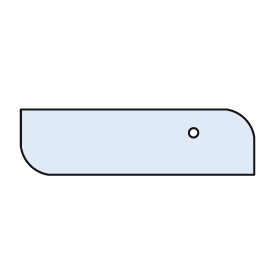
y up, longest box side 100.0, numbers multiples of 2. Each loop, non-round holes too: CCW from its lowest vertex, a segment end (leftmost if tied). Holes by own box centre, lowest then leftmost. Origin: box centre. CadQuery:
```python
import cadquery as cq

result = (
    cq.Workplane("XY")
    .moveTo(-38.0, -14.0)
    .lineTo(50.0, -14.0)
    .lineTo(50.0, 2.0)
    .threePointArc((46.0, 10.0), (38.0, 14.0))
    .lineTo(-50.0, 14.0)
    .lineTo(-50.0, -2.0)
    .threePointArc((-46.0, -10.0), (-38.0, -14.0))
    .close()
    .moveTo(24.0, 4.0)
    .circle(2.0)
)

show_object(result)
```